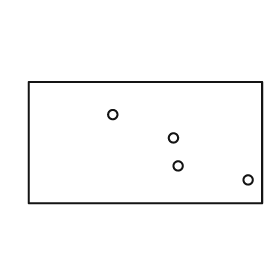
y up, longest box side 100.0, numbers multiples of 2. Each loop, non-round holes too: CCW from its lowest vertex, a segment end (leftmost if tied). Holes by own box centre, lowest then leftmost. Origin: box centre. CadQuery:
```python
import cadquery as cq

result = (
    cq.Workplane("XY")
    .moveTo(-50.0, -26.0)
    .lineTo(50.0, -26.0)
    .lineTo(50.0, 26.0)
    .lineTo(-50.0, 26.0)
    .close()
    .moveTo(44.0, -16.0)
    .circle(2.0)
    .moveTo(14.0, -10.0)
    .circle(2.0)
    .moveTo(12.0, 2.0)
    .circle(2.0)
    .moveTo(-14.0, 12.0)
    .circle(2.0)
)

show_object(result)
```